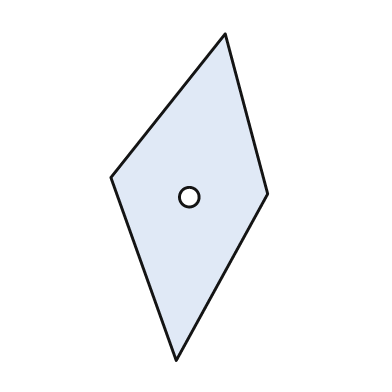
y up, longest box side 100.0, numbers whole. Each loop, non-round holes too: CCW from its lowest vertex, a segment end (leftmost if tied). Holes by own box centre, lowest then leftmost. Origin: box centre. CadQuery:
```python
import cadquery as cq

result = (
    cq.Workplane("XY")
    .moveTo(-4.0, -50.0)
    .lineTo(24.0, 1.0)
    .lineTo(11.0, 50.0)
    .lineTo(-24.0, 6.0)
    .close()
    .moveTo(0.0, 0.0)
    .circle(3.0)
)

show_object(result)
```